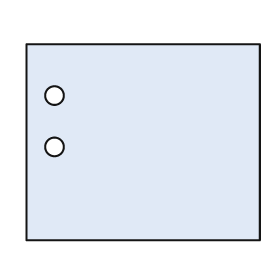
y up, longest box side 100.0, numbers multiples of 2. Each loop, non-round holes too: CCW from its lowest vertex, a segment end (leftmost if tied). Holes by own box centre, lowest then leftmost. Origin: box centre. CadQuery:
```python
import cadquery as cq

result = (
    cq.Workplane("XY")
    .moveTo(-50.0, -42.0)
    .lineTo(50.0, -42.0)
    .lineTo(50.0, 42.0)
    .lineTo(-50.0, 42.0)
    .close()
    .moveTo(-38.0, -2.0)
    .circle(4.0)
    .moveTo(-38.0, 20.0)
    .circle(4.0)
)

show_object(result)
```